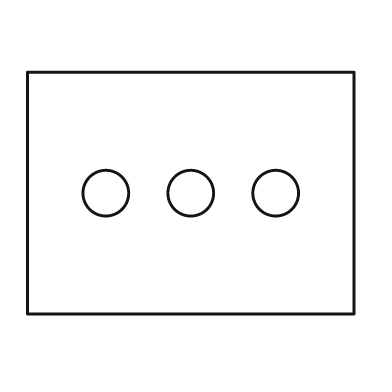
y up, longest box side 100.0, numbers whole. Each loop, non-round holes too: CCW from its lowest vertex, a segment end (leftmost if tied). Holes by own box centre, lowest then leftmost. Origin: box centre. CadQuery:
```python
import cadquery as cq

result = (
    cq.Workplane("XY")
    .moveTo(-50.0, -37.0)
    .lineTo(50.0, -37.0)
    .lineTo(50.0, 37.0)
    .lineTo(-50.0, 37.0)
    .close()
    .moveTo(-26.0, 0.0)
    .circle(7.0)
    .moveTo(0.0, 0.0)
    .circle(7.0)
    .moveTo(26.0, 0.0)
    .circle(7.0)
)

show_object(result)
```